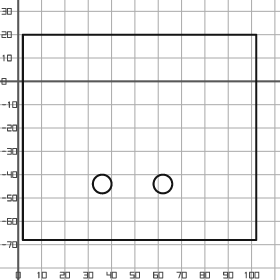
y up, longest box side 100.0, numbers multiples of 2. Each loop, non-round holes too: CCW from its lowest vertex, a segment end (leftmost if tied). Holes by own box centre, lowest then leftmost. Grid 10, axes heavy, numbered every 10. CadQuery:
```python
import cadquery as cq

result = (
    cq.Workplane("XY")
    .moveTo(2.0, -68.0)
    .lineTo(102.0, -68.0)
    .lineTo(102.0, 20.0)
    .lineTo(2.0, 20.0)
    .close()
    .moveTo(36.0, -44.0)
    .circle(4.0)
    .moveTo(62.0, -44.0)
    .circle(4.0)
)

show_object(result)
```